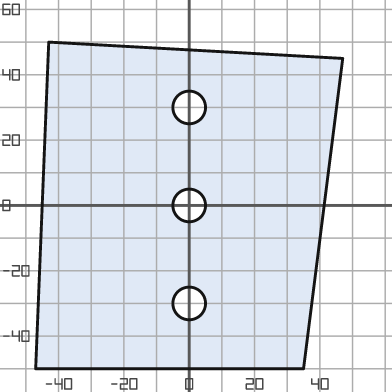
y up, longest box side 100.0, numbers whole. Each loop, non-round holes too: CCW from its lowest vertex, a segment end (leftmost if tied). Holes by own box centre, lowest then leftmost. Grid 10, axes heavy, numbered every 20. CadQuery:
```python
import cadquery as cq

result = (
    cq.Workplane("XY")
    .moveTo(-47.0, -50.0)
    .lineTo(35.0, -50.0)
    .lineTo(47.0, 45.0)
    .lineTo(-43.0, 50.0)
    .close()
    .moveTo(0.0, -30.0)
    .circle(5.0)
    .moveTo(0.0, 0.0)
    .circle(5.0)
    .moveTo(0.0, 30.0)
    .circle(5.0)
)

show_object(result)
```